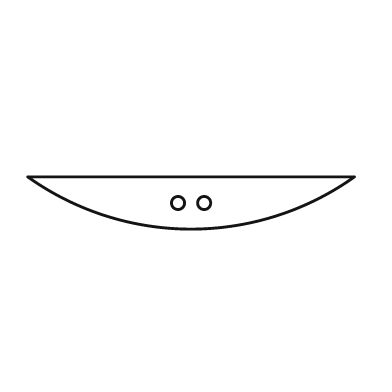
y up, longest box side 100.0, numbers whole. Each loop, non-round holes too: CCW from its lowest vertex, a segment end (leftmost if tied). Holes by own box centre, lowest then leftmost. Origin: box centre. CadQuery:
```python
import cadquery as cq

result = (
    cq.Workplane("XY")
    .moveTo(-50.0, 8.0)
    .threePointArc((0.0, -8.0), (50.0, 8.0))
    .close()
    .moveTo(-4.0, 0.0)
    .circle(2.0)
    .moveTo(4.0, 0.0)
    .circle(2.0)
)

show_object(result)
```